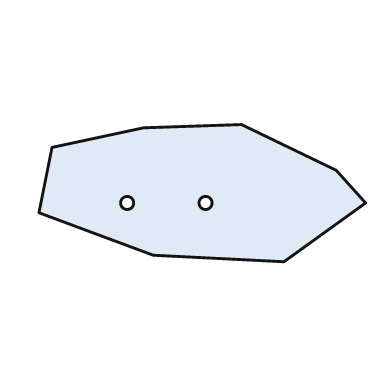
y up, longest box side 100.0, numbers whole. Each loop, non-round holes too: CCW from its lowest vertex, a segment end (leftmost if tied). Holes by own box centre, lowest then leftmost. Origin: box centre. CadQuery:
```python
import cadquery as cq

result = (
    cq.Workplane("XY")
    .moveTo(25.0, -21.0)
    .lineTo(50.0, -3.0)
    .lineTo(41.0, 7.0)
    .lineTo(12.0, 21.0)
    .lineTo(-18.0, 20.0)
    .lineTo(-46.0, 14.0)
    .lineTo(-50.0, -6.0)
    .lineTo(-15.0, -19.0)
    .close()
    .moveTo(-23.0, -3.0)
    .circle(2.0)
    .moveTo(1.0, -3.0)
    .circle(2.0)
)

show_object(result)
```